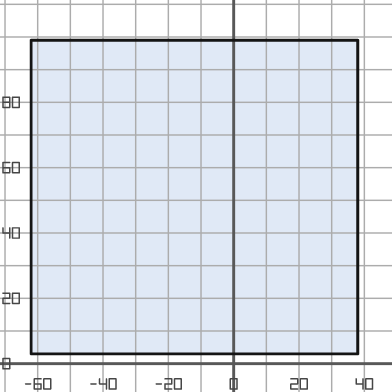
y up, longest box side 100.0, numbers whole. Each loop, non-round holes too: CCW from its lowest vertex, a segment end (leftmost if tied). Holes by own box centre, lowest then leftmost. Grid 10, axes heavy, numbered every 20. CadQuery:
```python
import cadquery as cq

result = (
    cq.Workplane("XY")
    .moveTo(-62.0, 3.0)
    .lineTo(38.0, 3.0)
    .lineTo(38.0, 99.0)
    .lineTo(-62.0, 99.0)
    .close()
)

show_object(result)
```